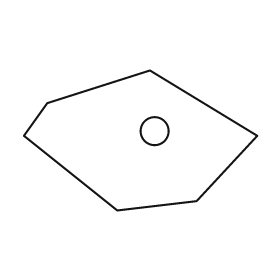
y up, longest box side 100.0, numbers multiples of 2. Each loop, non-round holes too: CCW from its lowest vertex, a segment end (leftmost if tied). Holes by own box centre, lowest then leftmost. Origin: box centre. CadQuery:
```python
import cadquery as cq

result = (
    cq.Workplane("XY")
    .moveTo(-10.0, -30.0)
    .lineTo(24.0, -26.0)
    .lineTo(50.0, 2.0)
    .lineTo(4.0, 30.0)
    .lineTo(-40.0, 16.0)
    .lineTo(-50.0, 2.0)
    .close()
    .moveTo(6.0, 4.0)
    .circle(6.0)
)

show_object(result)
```